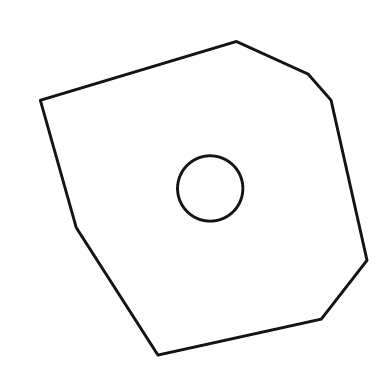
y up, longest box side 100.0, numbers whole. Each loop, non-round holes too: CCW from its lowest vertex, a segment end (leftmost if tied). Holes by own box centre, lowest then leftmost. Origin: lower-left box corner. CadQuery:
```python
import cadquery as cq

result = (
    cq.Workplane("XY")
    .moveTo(36.0, 0.0)
    .lineTo(86.0, 11.0)
    .lineTo(100.0, 29.0)
    .lineTo(89.0, 78.0)
    .lineTo(82.0, 86.0)
    .lineTo(60.0, 96.0)
    .lineTo(0.0, 78.0)
    .lineTo(11.0, 39.0)
    .close()
    .moveTo(52.0, 51.0)
    .circle(10.0)
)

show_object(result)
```